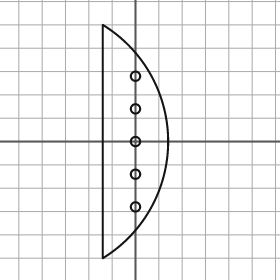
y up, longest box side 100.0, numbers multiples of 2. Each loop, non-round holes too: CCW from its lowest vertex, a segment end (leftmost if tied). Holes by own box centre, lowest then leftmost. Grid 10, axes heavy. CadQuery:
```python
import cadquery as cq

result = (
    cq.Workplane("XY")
    .moveTo(-14.0, -50.0)
    .threePointArc((14.0, 0.0), (-14.0, 50.0))
    .close()
    .moveTo(0.0, -28.0)
    .circle(2.0)
    .moveTo(0.0, -14.0)
    .circle(2.0)
    .moveTo(0.0, 0.0)
    .circle(2.0)
    .moveTo(0.0, 14.0)
    .circle(2.0)
    .moveTo(0.0, 28.0)
    .circle(2.0)
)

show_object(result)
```